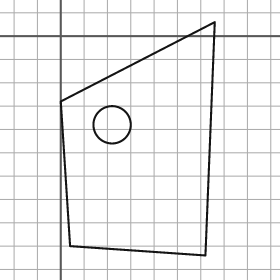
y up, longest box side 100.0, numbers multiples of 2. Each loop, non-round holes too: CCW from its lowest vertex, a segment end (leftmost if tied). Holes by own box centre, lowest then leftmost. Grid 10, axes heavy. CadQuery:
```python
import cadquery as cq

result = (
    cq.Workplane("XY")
    .moveTo(62.0, -94.0)
    .lineTo(66.0, 6.0)
    .lineTo(0.0, -28.0)
    .lineTo(4.0, -90.0)
    .close()
    .moveTo(22.0, -38.0)
    .circle(8.0)
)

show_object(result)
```